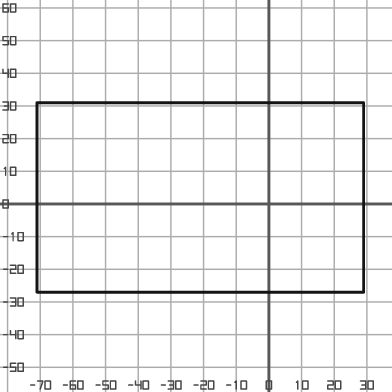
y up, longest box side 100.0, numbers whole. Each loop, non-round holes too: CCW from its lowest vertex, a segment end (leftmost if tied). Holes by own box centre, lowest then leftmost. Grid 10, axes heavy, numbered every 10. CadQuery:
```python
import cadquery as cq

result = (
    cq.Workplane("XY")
    .moveTo(-71.0, -27.0)
    .lineTo(29.0, -27.0)
    .lineTo(29.0, 31.0)
    .lineTo(-71.0, 31.0)
    .close()
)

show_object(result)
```